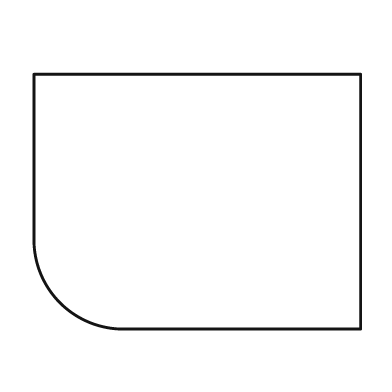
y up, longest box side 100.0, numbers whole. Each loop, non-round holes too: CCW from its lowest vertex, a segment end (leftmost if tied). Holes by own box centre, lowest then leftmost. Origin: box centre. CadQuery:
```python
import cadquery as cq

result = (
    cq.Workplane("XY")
    .moveTo(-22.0, -39.0)
    .lineTo(50.0, -39.0)
    .lineTo(50.0, 39.0)
    .lineTo(-50.0, 39.0)
    .lineTo(-50.0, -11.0)
    .threePointArc((-42.0, -31.0), (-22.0, -39.0))
    .close()
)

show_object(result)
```